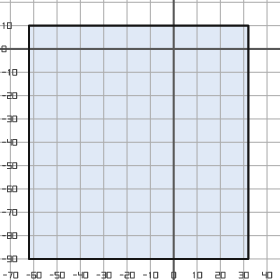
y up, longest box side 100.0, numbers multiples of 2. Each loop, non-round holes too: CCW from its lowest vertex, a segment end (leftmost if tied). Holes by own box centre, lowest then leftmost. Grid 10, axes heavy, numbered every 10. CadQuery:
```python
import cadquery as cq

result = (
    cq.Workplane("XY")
    .moveTo(-62.0, -90.0)
    .lineTo(32.0, -90.0)
    .lineTo(32.0, 10.0)
    .lineTo(-62.0, 10.0)
    .close()
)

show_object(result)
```